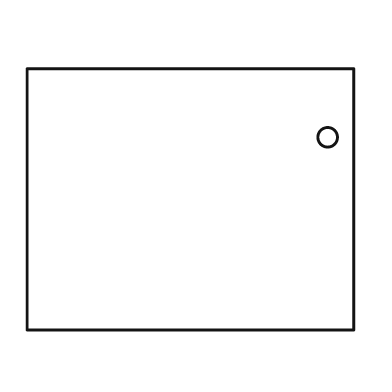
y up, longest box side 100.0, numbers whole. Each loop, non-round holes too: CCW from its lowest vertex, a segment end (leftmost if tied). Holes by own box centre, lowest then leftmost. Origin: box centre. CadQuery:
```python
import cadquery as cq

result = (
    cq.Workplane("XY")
    .moveTo(-50.0, -40.0)
    .lineTo(50.0, -40.0)
    .lineTo(50.0, 40.0)
    .lineTo(-50.0, 40.0)
    .close()
    .moveTo(42.0, 19.0)
    .circle(3.0)
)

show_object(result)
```